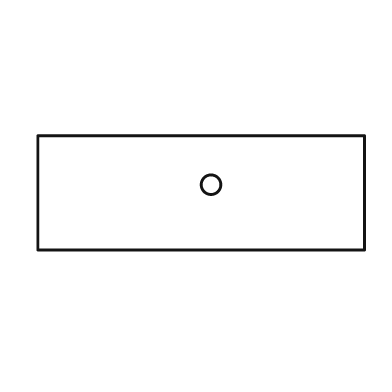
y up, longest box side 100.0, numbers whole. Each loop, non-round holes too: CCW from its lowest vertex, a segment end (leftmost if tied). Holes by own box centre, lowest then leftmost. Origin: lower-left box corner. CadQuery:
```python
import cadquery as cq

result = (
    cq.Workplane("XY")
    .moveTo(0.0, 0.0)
    .lineTo(100.0, 0.0)
    .lineTo(100.0, 35.0)
    .lineTo(0.0, 35.0)
    .close()
    .moveTo(53.0, 20.0)
    .circle(3.0)
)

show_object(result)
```